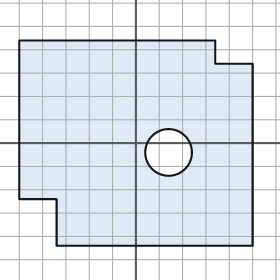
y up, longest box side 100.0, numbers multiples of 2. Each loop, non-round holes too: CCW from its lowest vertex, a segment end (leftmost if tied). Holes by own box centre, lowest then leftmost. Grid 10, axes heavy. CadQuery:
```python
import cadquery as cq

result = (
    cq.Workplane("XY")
    .moveTo(-34.0, -44.0)
    .lineTo(50.0, -44.0)
    .lineTo(50.0, 34.0)
    .lineTo(34.0, 34.0)
    .lineTo(34.0, 44.0)
    .lineTo(-50.0, 44.0)
    .lineTo(-50.0, -24.0)
    .lineTo(-34.0, -24.0)
    .close()
    .moveTo(14.0, -4.0)
    .circle(10.0)
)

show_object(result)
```